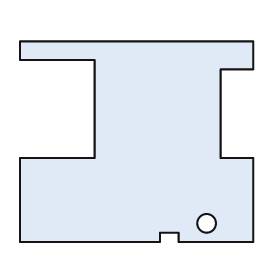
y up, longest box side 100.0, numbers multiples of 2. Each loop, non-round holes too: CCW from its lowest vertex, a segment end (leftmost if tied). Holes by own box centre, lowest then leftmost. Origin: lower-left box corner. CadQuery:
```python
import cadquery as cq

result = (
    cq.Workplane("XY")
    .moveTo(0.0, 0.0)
    .lineTo(60.0, 0.0)
    .lineTo(60.0, 4.0)
    .lineTo(68.0, 4.0)
    .lineTo(68.0, 0.0)
    .lineTo(100.0, 0.0)
    .lineTo(100.0, 36.0)
    .lineTo(86.0, 36.0)
    .lineTo(86.0, 74.0)
    .lineTo(100.0, 74.0)
    .lineTo(100.0, 86.0)
    .lineTo(0.0, 86.0)
    .lineTo(0.0, 78.0)
    .lineTo(32.0, 78.0)
    .lineTo(32.0, 36.0)
    .lineTo(0.0, 36.0)
    .close()
    .moveTo(80.0, 8.0)
    .circle(4.0)
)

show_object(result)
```